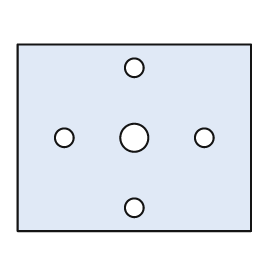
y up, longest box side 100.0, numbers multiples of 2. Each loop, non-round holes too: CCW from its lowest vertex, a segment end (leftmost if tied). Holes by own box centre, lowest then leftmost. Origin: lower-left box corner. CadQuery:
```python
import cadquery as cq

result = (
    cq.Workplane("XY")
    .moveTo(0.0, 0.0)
    .lineTo(100.0, 0.0)
    .lineTo(100.0, 80.0)
    .lineTo(0.0, 80.0)
    .close()
    .moveTo(50.0, 10.0)
    .circle(4.0)
    .moveTo(20.0, 40.0)
    .circle(4.0)
    .moveTo(50.0, 40.0)
    .circle(6.0)
    .moveTo(80.0, 40.0)
    .circle(4.0)
    .moveTo(50.0, 70.0)
    .circle(4.0)
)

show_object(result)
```